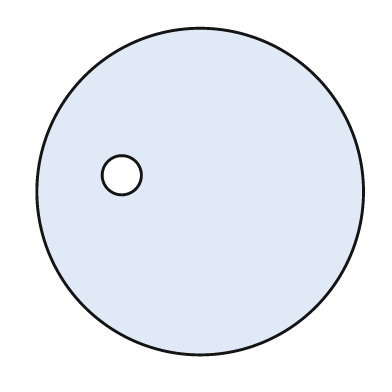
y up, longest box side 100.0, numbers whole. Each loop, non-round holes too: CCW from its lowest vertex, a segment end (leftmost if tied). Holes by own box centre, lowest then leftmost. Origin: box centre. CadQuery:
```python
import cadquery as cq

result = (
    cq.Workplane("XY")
    .moveTo(0.0, 0.0)
    .circle(50.0)
    .moveTo(-24.0, 5.0)
    .circle(6.0)
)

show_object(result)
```